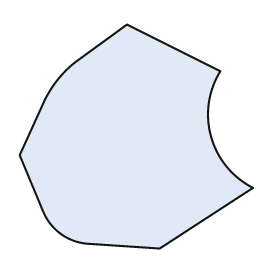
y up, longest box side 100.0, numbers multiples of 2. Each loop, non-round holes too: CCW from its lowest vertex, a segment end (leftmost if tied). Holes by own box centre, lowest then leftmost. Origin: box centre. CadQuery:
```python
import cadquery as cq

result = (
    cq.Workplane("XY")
    .moveTo(10.0, -48.0)
    .lineTo(50.0, -22.0)
    .threePointArc((32.0, 0.0), (36.0, 28.0))
    .lineTo(-4.0, 48.0)
    .lineTo(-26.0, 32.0)
    .threePointArc((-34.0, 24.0), (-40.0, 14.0))
    .lineTo(-50.0, -8.0)
    .lineTo(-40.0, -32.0)
    .threePointArc((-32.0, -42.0), (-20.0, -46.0))
    .close()
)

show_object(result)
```